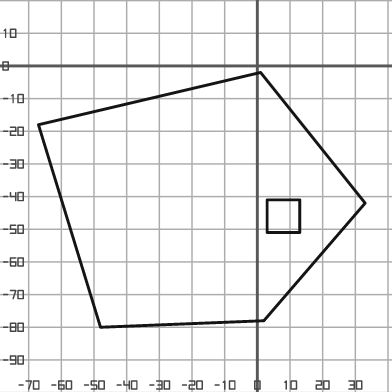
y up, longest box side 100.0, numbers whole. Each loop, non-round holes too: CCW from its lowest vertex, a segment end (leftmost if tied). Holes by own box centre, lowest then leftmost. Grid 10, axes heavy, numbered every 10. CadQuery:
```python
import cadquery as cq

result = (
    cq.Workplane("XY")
    .moveTo(-48.0, -80.0)
    .lineTo(2.0, -78.0)
    .lineTo(33.0, -42.0)
    .lineTo(1.0, -2.0)
    .lineTo(-67.0, -18.0)
    .close()
    .moveTo(3.0, -51.0)
    .lineTo(13.0, -51.0)
    .lineTo(13.0, -41.0)
    .lineTo(3.0, -41.0)
    .close()
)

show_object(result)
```